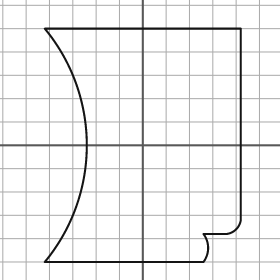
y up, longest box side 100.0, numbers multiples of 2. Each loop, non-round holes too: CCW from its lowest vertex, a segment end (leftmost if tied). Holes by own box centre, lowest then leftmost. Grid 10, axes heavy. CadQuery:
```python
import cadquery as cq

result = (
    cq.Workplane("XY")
    .moveTo(-42.0, -50.0)
    .lineTo(26.0, -50.0)
    .threePointArc((28.0, -44.0), (26.0, -38.0))
    .lineTo(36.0, -38.0)
    .threePointArc((40.0, -36.0), (42.0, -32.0))
    .lineTo(42.0, 50.0)
    .lineTo(-42.0, 50.0)
    .threePointArc((-24.0, 0.0), (-42.0, -50.0))
    .close()
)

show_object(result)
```